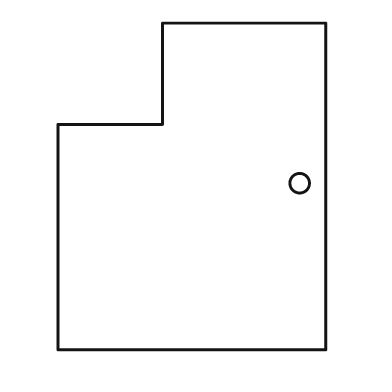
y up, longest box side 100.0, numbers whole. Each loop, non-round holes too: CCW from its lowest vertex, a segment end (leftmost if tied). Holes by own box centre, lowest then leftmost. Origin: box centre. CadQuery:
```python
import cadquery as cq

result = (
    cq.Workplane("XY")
    .moveTo(-41.0, -50.0)
    .lineTo(41.0, -50.0)
    .lineTo(41.0, 50.0)
    .lineTo(-9.0, 50.0)
    .lineTo(-9.0, 19.0)
    .lineTo(-41.0, 19.0)
    .close()
    .moveTo(33.0, 1.0)
    .circle(3.0)
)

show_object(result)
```